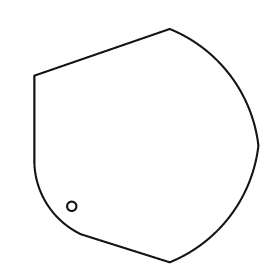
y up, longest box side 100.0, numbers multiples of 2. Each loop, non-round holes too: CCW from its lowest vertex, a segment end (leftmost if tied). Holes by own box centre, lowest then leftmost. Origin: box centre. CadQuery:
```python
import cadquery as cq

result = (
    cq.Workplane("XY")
    .moveTo(10.0, -50.0)
    .threePointArc((36.0, -30.0), (48.0, 0.0))
    .threePointArc((36.0, 30.0), (10.0, 50.0))
    .lineTo(-48.0, 30.0)
    .lineTo(-48.0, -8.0)
    .threePointArc((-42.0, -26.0), (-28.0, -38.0))
    .close()
    .moveTo(-32.0, -26.0)
    .circle(2.0)
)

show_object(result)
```